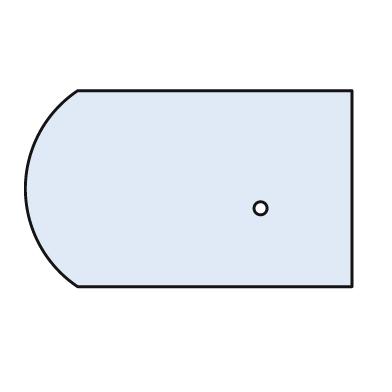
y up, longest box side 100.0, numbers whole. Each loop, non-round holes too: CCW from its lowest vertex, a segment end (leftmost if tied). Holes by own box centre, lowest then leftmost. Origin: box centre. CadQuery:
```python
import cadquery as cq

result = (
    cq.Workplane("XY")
    .moveTo(-34.0, -30.0)
    .lineTo(50.0, -30.0)
    .lineTo(50.0, 30.0)
    .lineTo(-34.0, 30.0)
    .threePointArc((-50.0, 0.0), (-34.0, -30.0))
    .close()
    .moveTo(22.0, -6.0)
    .circle(2.0)
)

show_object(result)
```